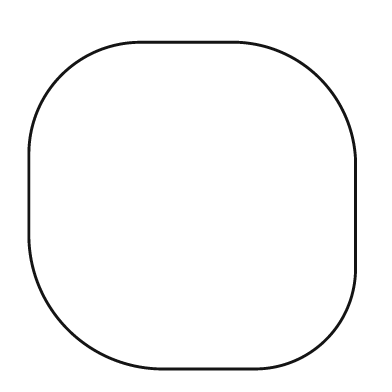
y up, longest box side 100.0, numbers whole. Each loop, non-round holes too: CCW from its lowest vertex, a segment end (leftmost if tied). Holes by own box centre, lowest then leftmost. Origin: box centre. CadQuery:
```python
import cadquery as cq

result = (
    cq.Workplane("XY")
    .moveTo(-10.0, -50.0)
    .lineTo(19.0, -50.0)
    .threePointArc((41.0, -41.0), (50.0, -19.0))
    .lineTo(50.0, 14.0)
    .threePointArc((39.0, 39.0), (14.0, 50.0))
    .lineTo(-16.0, 50.0)
    .threePointArc((-40.0, 40.0), (-50.0, 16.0))
    .lineTo(-50.0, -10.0)
    .threePointArc((-38.0, -38.0), (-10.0, -50.0))
    .close()
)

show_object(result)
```